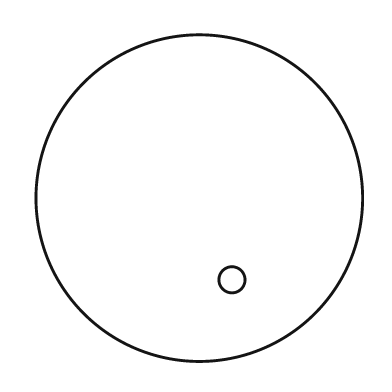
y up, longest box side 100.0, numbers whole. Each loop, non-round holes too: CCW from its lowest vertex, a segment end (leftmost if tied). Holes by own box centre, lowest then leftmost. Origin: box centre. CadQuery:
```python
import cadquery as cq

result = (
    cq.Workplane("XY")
    .moveTo(0.0, 0.0)
    .circle(50.0)
    .moveTo(10.0, -25.0)
    .circle(4.0)
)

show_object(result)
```